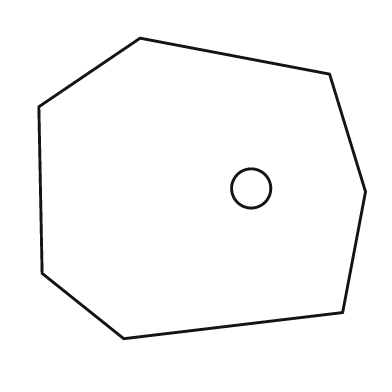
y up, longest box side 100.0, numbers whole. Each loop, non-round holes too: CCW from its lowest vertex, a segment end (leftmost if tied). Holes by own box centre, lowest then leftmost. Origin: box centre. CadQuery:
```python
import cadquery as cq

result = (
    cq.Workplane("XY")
    .moveTo(-24.0, -46.0)
    .lineTo(43.0, -38.0)
    .lineTo(50.0, -1.0)
    .lineTo(39.0, 35.0)
    .lineTo(-19.0, 46.0)
    .lineTo(-50.0, 25.0)
    .lineTo(-49.0, -26.0)
    .close()
    .moveTo(15.0, 0.0)
    .circle(6.0)
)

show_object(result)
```